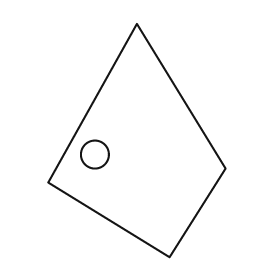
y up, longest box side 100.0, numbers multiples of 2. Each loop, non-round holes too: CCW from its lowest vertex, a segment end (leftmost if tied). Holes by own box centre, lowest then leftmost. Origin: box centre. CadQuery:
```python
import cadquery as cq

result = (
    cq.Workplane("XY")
    .moveTo(14.0, -50.0)
    .lineTo(38.0, -12.0)
    .lineTo(0.0, 50.0)
    .lineTo(-38.0, -18.0)
    .close()
    .moveTo(-18.0, -6.0)
    .circle(6.0)
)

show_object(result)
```